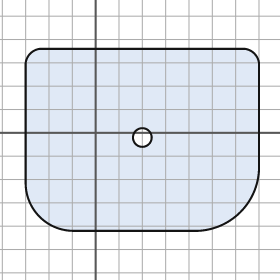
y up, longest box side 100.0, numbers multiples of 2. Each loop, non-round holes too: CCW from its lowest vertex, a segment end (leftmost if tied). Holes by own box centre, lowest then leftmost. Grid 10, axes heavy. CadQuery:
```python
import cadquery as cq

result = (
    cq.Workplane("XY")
    .moveTo(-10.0, -42.0)
    .lineTo(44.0, -42.0)
    .threePointArc((62.0, -34.0), (70.0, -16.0))
    .lineTo(70.0, 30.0)
    .threePointArc((68.0, 34.0), (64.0, 36.0))
    .lineTo(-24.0, 36.0)
    .threePointArc((-28.0, 34.0), (-30.0, 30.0))
    .lineTo(-30.0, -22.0)
    .threePointArc((-24.0, -36.0), (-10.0, -42.0))
    .close()
    .moveTo(20.0, -2.0)
    .circle(4.0)
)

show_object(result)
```